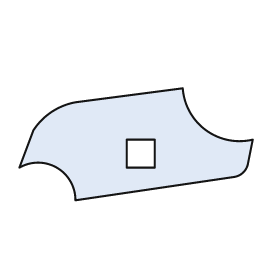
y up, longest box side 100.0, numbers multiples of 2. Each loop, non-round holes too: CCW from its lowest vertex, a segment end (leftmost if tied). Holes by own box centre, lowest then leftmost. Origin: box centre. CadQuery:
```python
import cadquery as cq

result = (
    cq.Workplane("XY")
    .moveTo(-26.0, -24.0)
    .lineTo(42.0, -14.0)
    .threePointArc((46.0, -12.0), (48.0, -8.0))
    .lineTo(50.0, 2.0)
    .threePointArc((30.0, 6.0), (20.0, 24.0))
    .lineTo(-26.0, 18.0)
    .threePointArc((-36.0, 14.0), (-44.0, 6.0))
    .lineTo(-50.0, -10.0)
    .threePointArc((-34.0, -10.0), (-26.0, -24.0))
    .close()
    .moveTo(-4.0, -10.0)
    .lineTo(8.0, -10.0)
    .lineTo(8.0, 2.0)
    .lineTo(-4.0, 2.0)
    .close()
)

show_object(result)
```